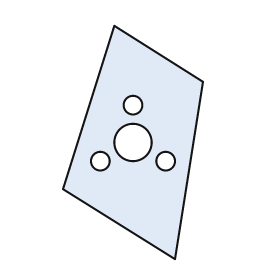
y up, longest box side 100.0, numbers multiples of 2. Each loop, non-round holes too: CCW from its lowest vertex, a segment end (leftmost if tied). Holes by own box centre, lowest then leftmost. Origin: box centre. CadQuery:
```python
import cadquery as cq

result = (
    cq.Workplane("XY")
    .moveTo(18.0, -50.0)
    .lineTo(30.0, 26.0)
    .lineTo(-8.0, 50.0)
    .lineTo(-30.0, -20.0)
    .close()
    .moveTo(-14.0, -8.0)
    .circle(4.0)
    .moveTo(14.0, -8.0)
    .circle(4.0)
    .moveTo(0.0, 0.0)
    .circle(8.0)
    .moveTo(0.0, 16.0)
    .circle(4.0)
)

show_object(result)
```